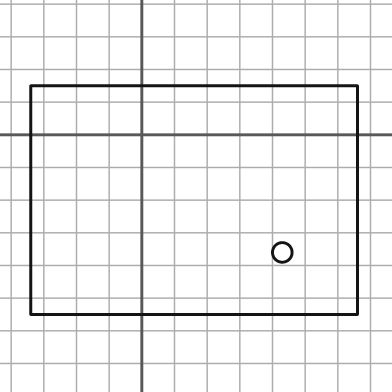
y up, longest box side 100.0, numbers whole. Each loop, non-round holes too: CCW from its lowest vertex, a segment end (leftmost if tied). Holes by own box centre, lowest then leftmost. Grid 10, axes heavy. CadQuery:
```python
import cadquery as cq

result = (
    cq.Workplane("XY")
    .moveTo(-34.0, -55.0)
    .lineTo(66.0, -55.0)
    .lineTo(66.0, 15.0)
    .lineTo(-34.0, 15.0)
    .close()
    .moveTo(43.0, -36.0)
    .circle(3.0)
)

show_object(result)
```